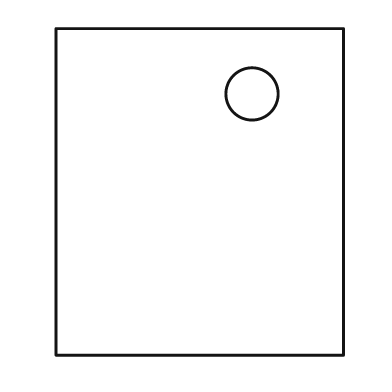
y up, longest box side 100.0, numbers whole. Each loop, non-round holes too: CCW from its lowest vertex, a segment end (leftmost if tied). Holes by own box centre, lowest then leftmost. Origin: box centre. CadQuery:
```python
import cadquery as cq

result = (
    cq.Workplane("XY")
    .moveTo(-44.0, -50.0)
    .lineTo(44.0, -50.0)
    .lineTo(44.0, 50.0)
    .lineTo(-44.0, 50.0)
    .close()
    .moveTo(16.0, 30.0)
    .circle(8.0)
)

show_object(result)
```